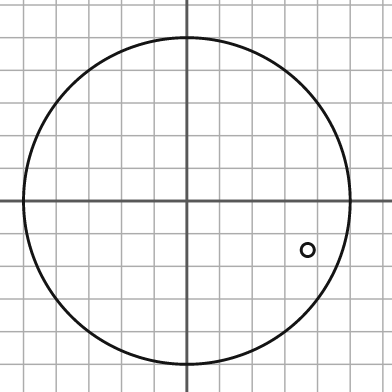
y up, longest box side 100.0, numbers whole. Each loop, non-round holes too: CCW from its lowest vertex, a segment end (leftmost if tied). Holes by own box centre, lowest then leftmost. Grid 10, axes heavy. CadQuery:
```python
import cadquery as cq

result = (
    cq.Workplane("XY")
    .moveTo(0.0, 0.0)
    .circle(50.0)
    .moveTo(37.0, -15.0)
    .circle(2.0)
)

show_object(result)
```